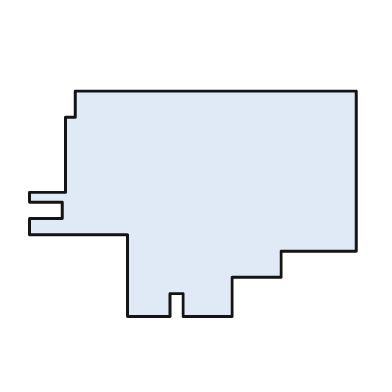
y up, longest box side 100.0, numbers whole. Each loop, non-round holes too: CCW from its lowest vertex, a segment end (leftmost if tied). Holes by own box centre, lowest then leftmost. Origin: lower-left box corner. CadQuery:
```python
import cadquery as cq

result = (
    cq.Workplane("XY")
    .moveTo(30.0, 0.0)
    .lineTo(43.0, 0.0)
    .lineTo(43.0, 7.0)
    .lineTo(47.0, 7.0)
    .lineTo(47.0, 0.0)
    .lineTo(62.0, 0.0)
    .lineTo(62.0, 12.0)
    .lineTo(77.0, 12.0)
    .lineTo(77.0, 20.0)
    .lineTo(100.0, 20.0)
    .lineTo(100.0, 69.0)
    .lineTo(14.0, 69.0)
    .lineTo(14.0, 61.0)
    .lineTo(11.0, 61.0)
    .lineTo(11.0, 38.0)
    .lineTo(0.0, 38.0)
    .lineTo(0.0, 35.0)
    .lineTo(10.0, 35.0)
    .lineTo(10.0, 30.0)
    .lineTo(0.0, 30.0)
    .lineTo(0.0, 25.0)
    .lineTo(30.0, 25.0)
    .close()
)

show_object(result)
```